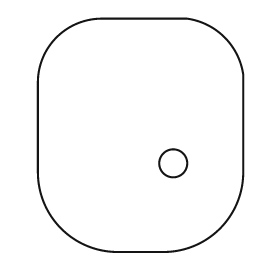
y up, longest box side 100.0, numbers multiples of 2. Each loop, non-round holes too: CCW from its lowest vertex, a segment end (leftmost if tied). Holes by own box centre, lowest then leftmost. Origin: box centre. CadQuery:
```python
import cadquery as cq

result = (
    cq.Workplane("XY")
    .moveTo(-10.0, -50.0)
    .lineTo(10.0, -50.0)
    .threePointArc((34.0, -40.0), (44.0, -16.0))
    .lineTo(44.0, 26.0)
    .threePointArc((36.0, 42.0), (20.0, 50.0))
    .lineTo(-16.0, 50.0)
    .threePointArc((-36.0, 42.0), (-44.0, 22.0))
    .lineTo(-44.0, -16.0)
    .threePointArc((-34.0, -40.0), (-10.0, -50.0))
    .close()
    .moveTo(14.0, -12.0)
    .circle(6.0)
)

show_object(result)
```